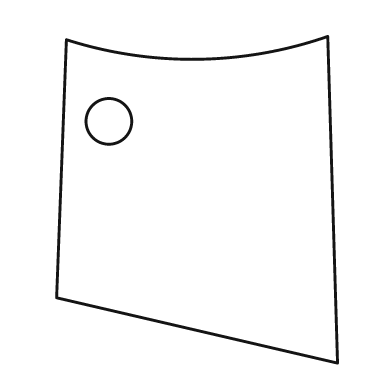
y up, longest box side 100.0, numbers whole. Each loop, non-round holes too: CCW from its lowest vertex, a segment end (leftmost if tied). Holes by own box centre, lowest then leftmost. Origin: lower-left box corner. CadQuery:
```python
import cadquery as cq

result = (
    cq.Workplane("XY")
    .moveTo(86.0, 0.0)
    .lineTo(83.0, 100.0)
    .threePointArc((43.0, 93.0), (3.0, 99.0))
    .lineTo(0.0, 20.0)
    .close()
    .moveTo(16.0, 74.0)
    .circle(7.0)
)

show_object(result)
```